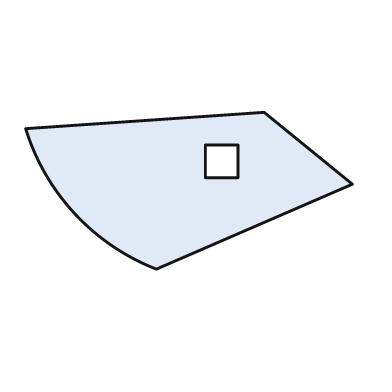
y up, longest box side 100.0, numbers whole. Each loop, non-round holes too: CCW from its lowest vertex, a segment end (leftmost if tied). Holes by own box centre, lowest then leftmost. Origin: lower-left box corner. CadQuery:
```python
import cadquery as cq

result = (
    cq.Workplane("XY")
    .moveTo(40.0, 0.0)
    .lineTo(100.0, 26.0)
    .lineTo(73.0, 48.0)
    .lineTo(0.0, 43.0)
    .threePointArc((15.0, 17.0), (40.0, 0.0))
    .close()
    .moveTo(55.0, 28.0)
    .lineTo(65.0, 28.0)
    .lineTo(65.0, 38.0)
    .lineTo(55.0, 38.0)
    .close()
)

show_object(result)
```